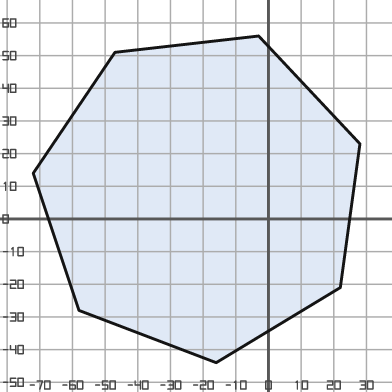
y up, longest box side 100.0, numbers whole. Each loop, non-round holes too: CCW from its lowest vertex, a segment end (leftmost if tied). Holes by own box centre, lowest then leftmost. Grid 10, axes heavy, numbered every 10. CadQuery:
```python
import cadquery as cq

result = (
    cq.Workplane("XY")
    .moveTo(-16.0, -44.0)
    .lineTo(22.0, -21.0)
    .lineTo(28.0, 23.0)
    .lineTo(-3.0, 56.0)
    .lineTo(-47.0, 51.0)
    .lineTo(-72.0, 14.0)
    .lineTo(-58.0, -28.0)
    .close()
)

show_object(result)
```